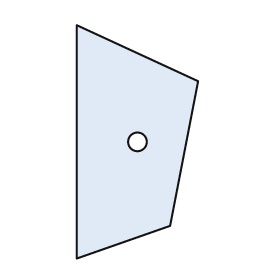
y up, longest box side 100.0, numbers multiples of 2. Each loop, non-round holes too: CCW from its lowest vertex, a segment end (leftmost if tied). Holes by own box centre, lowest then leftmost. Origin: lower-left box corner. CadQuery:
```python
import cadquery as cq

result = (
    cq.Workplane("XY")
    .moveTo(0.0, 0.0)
    .lineTo(40.0, 14.0)
    .lineTo(52.0, 76.0)
    .lineTo(0.0, 100.0)
    .close()
    .moveTo(26.0, 50.0)
    .circle(4.0)
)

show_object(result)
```